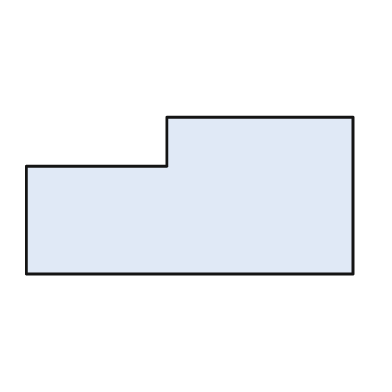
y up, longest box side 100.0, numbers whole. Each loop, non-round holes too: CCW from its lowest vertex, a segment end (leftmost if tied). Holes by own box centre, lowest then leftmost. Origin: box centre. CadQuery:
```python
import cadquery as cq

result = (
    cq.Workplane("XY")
    .moveTo(-50.0, -24.0)
    .lineTo(50.0, -24.0)
    .lineTo(50.0, 24.0)
    .lineTo(-7.0, 24.0)
    .lineTo(-7.0, 9.0)
    .lineTo(-50.0, 9.0)
    .close()
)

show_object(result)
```